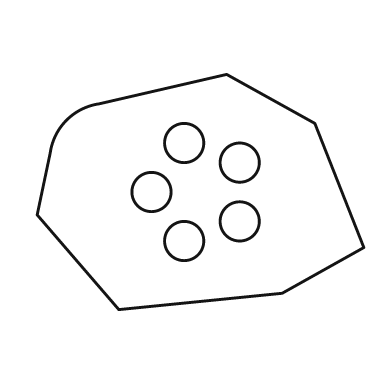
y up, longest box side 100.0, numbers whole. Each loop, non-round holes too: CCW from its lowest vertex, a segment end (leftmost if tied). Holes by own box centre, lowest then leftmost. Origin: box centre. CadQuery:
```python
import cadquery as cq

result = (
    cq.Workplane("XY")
    .moveTo(-25.0, -36.0)
    .lineTo(25.0, -31.0)
    .lineTo(50.0, -17.0)
    .lineTo(35.0, 21.0)
    .lineTo(8.0, 36.0)
    .lineTo(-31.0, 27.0)
    .threePointArc((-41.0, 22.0), (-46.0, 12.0))
    .lineTo(-50.0, -7.0)
    .close()
    .moveTo(-5.0, -15.0)
    .circle(6.0)
    .moveTo(12.0, -9.0)
    .circle(6.0)
    .moveTo(-15.0, 0.0)
    .circle(6.0)
    .moveTo(12.0, 9.0)
    .circle(6.0)
    .moveTo(-5.0, 15.0)
    .circle(6.0)
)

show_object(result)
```